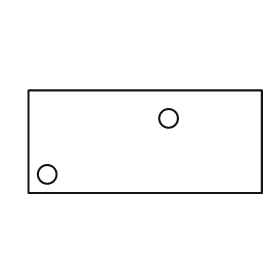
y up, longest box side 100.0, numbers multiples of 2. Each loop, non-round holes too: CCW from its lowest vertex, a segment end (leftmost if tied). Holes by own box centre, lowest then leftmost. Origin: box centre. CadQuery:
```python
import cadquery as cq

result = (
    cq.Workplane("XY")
    .moveTo(-50.0, -22.0)
    .lineTo(50.0, -22.0)
    .lineTo(50.0, 22.0)
    .lineTo(-50.0, 22.0)
    .close()
    .moveTo(-42.0, -14.0)
    .circle(4.0)
    .moveTo(10.0, 10.0)
    .circle(4.0)
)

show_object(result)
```